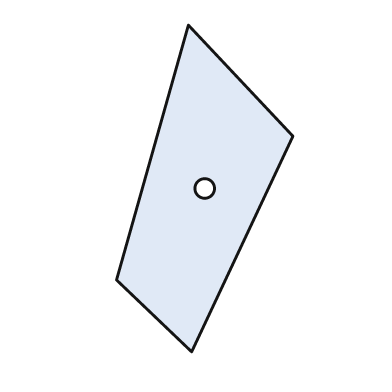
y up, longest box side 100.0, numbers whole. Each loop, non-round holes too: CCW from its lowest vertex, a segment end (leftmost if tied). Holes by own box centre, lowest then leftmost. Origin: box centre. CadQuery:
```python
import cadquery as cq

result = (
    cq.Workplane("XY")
    .moveTo(-4.0, -50.0)
    .lineTo(27.0, 16.0)
    .lineTo(-5.0, 50.0)
    .lineTo(-27.0, -28.0)
    .close()
    .moveTo(0.0, 0.0)
    .circle(3.0)
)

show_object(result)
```